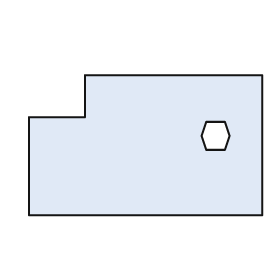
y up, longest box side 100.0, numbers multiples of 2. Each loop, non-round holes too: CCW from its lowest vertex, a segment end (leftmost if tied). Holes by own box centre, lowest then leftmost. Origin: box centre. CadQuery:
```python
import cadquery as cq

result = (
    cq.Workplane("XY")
    .moveTo(-50.0, -30.0)
    .lineTo(50.0, -30.0)
    .lineTo(50.0, 30.0)
    .lineTo(-26.0, 30.0)
    .lineTo(-26.0, 12.0)
    .lineTo(-50.0, 12.0)
    .close()
    .moveTo(26.0, -2.0)
    .lineTo(34.0, -2.0)
    .lineTo(36.0, 4.0)
    .lineTo(34.0, 10.0)
    .lineTo(26.0, 10.0)
    .lineTo(24.0, 4.0)
    .close()
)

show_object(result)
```